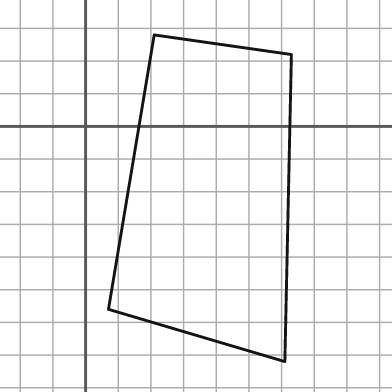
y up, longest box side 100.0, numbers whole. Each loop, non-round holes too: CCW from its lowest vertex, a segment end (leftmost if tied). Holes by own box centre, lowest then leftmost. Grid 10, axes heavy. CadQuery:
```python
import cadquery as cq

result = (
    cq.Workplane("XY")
    .moveTo(61.0, -72.0)
    .lineTo(63.0, 22.0)
    .lineTo(21.0, 28.0)
    .lineTo(7.0, -56.0)
    .close()
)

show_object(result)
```